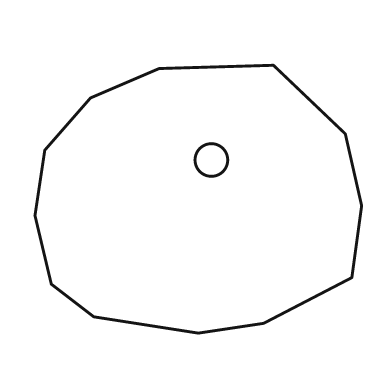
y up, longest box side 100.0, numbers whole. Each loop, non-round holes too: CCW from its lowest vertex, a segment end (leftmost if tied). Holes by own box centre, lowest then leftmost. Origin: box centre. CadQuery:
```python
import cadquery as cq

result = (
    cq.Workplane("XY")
    .moveTo(0.0, -41.0)
    .lineTo(20.0, -38.0)
    .lineTo(47.0, -24.0)
    .lineTo(50.0, -2.0)
    .lineTo(45.0, 20.0)
    .lineTo(23.0, 41.0)
    .lineTo(-12.0, 40.0)
    .lineTo(-33.0, 31.0)
    .lineTo(-47.0, 15.0)
    .lineTo(-50.0, -5.0)
    .lineTo(-45.0, -26.0)
    .lineTo(-32.0, -36.0)
    .close()
    .moveTo(4.0, 12.0)
    .circle(5.0)
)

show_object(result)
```